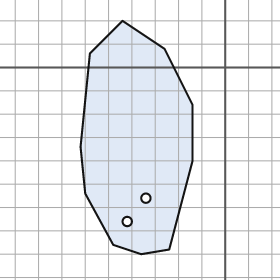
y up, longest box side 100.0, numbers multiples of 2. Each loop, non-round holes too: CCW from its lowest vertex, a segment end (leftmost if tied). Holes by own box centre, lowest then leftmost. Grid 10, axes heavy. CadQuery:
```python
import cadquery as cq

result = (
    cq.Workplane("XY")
    .moveTo(-36.0, -80.0)
    .lineTo(-24.0, -78.0)
    .lineTo(-14.0, -40.0)
    .lineTo(-14.0, -16.0)
    .lineTo(-26.0, 8.0)
    .lineTo(-44.0, 20.0)
    .lineTo(-58.0, 6.0)
    .lineTo(-62.0, -34.0)
    .lineTo(-60.0, -54.0)
    .lineTo(-48.0, -76.0)
    .close()
    .moveTo(-42.0, -66.0)
    .circle(2.0)
    .moveTo(-34.0, -56.0)
    .circle(2.0)
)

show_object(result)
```